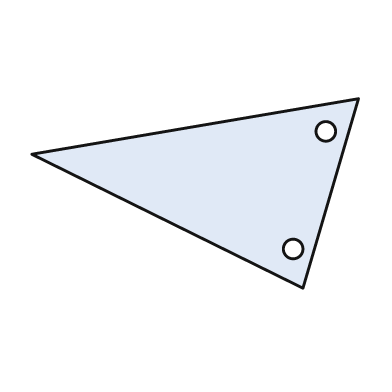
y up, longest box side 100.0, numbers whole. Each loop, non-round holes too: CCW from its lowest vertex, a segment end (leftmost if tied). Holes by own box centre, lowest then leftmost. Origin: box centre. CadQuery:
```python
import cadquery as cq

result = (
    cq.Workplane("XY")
    .moveTo(33.0, -29.0)
    .lineTo(50.0, 29.0)
    .lineTo(-50.0, 12.0)
    .close()
    .moveTo(30.0, -17.0)
    .circle(3.0)
    .moveTo(40.0, 19.0)
    .circle(3.0)
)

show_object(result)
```